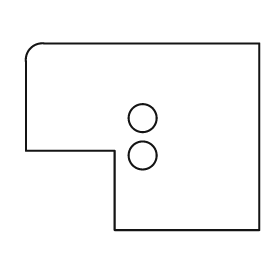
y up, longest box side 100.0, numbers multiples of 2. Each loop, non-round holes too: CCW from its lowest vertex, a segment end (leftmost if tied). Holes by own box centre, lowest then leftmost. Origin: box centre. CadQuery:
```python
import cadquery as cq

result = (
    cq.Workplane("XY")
    .moveTo(-12.0, -40.0)
    .lineTo(50.0, -40.0)
    .lineTo(50.0, 40.0)
    .lineTo(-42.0, 40.0)
    .threePointArc((-48.0, 38.0), (-50.0, 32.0))
    .lineTo(-50.0, -6.0)
    .lineTo(-12.0, -6.0)
    .close()
    .moveTo(0.0, -8.0)
    .circle(6.0)
    .moveTo(0.0, 8.0)
    .circle(6.0)
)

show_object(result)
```